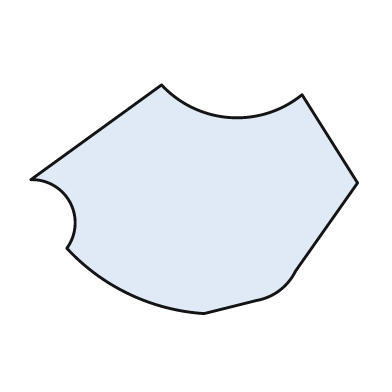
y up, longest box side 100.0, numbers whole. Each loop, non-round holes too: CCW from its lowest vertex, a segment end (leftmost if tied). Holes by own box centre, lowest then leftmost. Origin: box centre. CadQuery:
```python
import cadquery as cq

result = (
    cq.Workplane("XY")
    .moveTo(3.0, -35.0)
    .lineTo(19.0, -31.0)
    .threePointArc((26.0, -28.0), (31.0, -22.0))
    .lineTo(50.0, 5.0)
    .lineTo(33.0, 32.0)
    .threePointArc((11.0, 25.0), (-10.0, 35.0))
    .lineTo(-50.0, 6.0)
    .threePointArc((-38.0, -1.0), (-39.0, -15.0))
    .threePointArc((-20.0, -29.0), (3.0, -35.0))
    .close()
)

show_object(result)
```